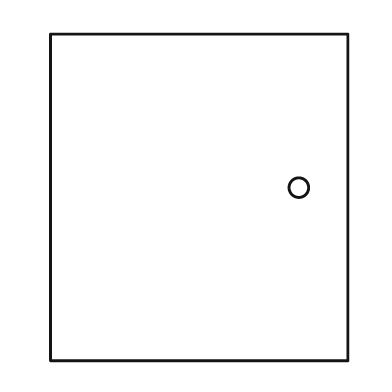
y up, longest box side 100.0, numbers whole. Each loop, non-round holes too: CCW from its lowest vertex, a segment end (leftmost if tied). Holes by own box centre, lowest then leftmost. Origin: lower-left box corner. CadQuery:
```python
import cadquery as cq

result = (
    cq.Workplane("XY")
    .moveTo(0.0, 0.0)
    .lineTo(91.0, 0.0)
    .lineTo(91.0, 100.0)
    .lineTo(0.0, 100.0)
    .close()
    .moveTo(76.0, 53.0)
    .circle(3.0)
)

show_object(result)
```